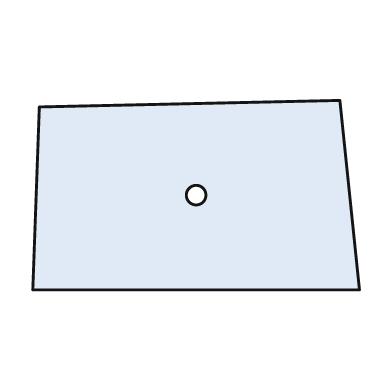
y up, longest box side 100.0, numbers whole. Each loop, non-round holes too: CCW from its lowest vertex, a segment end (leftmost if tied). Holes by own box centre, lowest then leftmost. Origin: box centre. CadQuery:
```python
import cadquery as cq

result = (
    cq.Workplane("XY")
    .moveTo(-50.0, -29.0)
    .lineTo(50.0, -29.0)
    .lineTo(44.0, 29.0)
    .lineTo(-48.0, 27.0)
    .close()
    .moveTo(0.0, 0.0)
    .circle(3.0)
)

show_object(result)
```